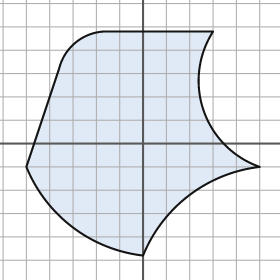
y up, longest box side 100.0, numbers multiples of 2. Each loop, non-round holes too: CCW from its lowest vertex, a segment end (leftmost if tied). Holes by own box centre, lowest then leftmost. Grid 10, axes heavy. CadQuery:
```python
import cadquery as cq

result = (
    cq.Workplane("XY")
    .moveTo(0.0, -48.0)
    .threePointArc((20.0, -22.0), (50.0, -10.0))
    .threePointArc((26.0, 14.0), (30.0, 48.0))
    .lineTo(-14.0, 48.0)
    .threePointArc((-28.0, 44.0), (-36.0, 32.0))
    .lineTo(-50.0, -10.0)
    .threePointArc((-30.0, -36.0), (0.0, -48.0))
    .close()
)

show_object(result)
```